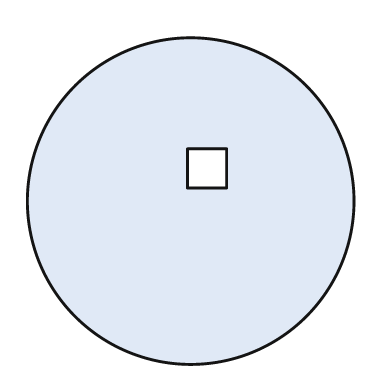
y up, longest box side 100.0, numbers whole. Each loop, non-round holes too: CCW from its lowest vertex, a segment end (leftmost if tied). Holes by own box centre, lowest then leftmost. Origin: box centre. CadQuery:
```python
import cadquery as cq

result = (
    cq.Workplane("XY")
    .moveTo(0.0, 0.0)
    .circle(50.0)
    .moveTo(-1.0, 4.0)
    .lineTo(11.0, 4.0)
    .lineTo(11.0, 16.0)
    .lineTo(-1.0, 16.0)
    .close()
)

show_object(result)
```